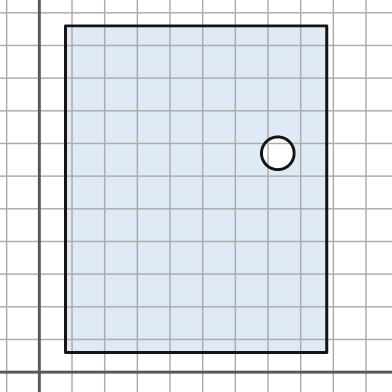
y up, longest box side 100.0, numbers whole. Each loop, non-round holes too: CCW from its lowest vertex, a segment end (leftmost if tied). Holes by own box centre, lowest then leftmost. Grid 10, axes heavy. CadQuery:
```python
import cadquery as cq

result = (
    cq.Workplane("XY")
    .moveTo(8.0, 6.0)
    .lineTo(88.0, 6.0)
    .lineTo(88.0, 106.0)
    .lineTo(8.0, 106.0)
    .close()
    .moveTo(73.0, 67.0)
    .circle(5.0)
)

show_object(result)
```